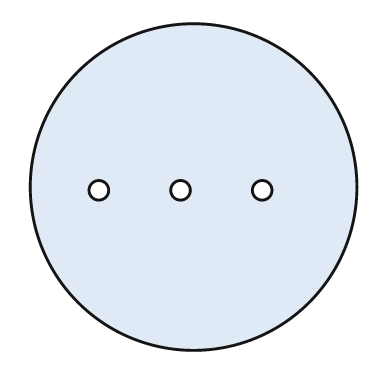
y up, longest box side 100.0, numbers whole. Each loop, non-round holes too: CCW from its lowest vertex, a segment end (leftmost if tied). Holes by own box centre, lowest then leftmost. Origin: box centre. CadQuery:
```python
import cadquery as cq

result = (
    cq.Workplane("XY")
    .moveTo(0.0, 0.0)
    .circle(50.0)
    .moveTo(-29.0, -1.0)
    .circle(3.0)
    .moveTo(-4.0, -1.0)
    .circle(3.0)
    .moveTo(21.0, -1.0)
    .circle(3.0)
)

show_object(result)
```